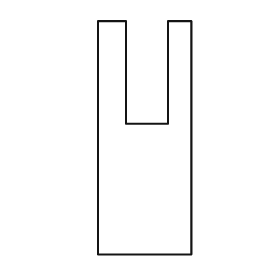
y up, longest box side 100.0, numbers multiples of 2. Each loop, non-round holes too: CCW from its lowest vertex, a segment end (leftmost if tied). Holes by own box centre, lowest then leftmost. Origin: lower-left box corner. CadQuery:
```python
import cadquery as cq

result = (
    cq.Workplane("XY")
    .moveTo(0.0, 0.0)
    .lineTo(40.0, 0.0)
    .lineTo(40.0, 100.0)
    .lineTo(30.0, 100.0)
    .lineTo(30.0, 56.0)
    .lineTo(12.0, 56.0)
    .lineTo(12.0, 100.0)
    .lineTo(0.0, 100.0)
    .close()
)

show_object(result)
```